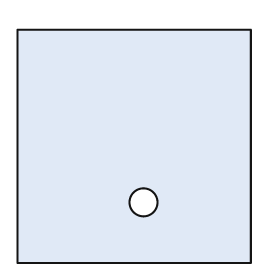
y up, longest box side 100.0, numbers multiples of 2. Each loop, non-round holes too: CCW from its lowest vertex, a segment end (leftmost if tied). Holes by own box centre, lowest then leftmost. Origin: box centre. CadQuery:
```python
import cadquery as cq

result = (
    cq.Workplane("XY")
    .moveTo(-50.0, -50.0)
    .lineTo(50.0, -50.0)
    .lineTo(50.0, 50.0)
    .lineTo(-50.0, 50.0)
    .close()
    .moveTo(4.0, -24.0)
    .circle(6.0)
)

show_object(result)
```